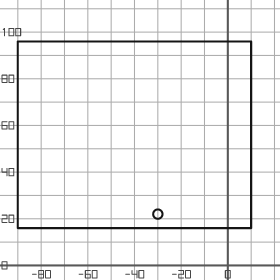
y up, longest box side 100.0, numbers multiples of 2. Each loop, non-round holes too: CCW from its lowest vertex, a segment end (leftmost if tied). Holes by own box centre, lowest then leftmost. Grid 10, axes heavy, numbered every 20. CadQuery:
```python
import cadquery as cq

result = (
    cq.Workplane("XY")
    .moveTo(-90.0, 16.0)
    .lineTo(10.0, 16.0)
    .lineTo(10.0, 96.0)
    .lineTo(-90.0, 96.0)
    .close()
    .moveTo(-30.0, 22.0)
    .circle(2.0)
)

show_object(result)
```